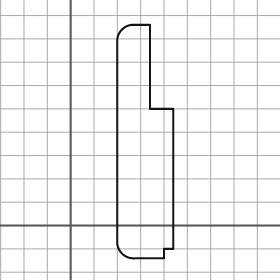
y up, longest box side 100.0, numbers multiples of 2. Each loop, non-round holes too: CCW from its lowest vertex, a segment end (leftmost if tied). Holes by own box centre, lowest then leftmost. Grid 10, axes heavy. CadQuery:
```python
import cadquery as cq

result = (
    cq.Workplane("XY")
    .moveTo(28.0, -14.0)
    .lineTo(40.0, -14.0)
    .lineTo(40.0, -10.0)
    .lineTo(44.0, -10.0)
    .lineTo(44.0, 50.0)
    .lineTo(34.0, 50.0)
    .lineTo(34.0, 86.0)
    .lineTo(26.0, 86.0)
    .threePointArc((22.0, 84.0), (20.0, 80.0))
    .lineTo(20.0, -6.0)
    .threePointArc((22.0, -12.0), (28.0, -14.0))
    .close()
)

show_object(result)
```